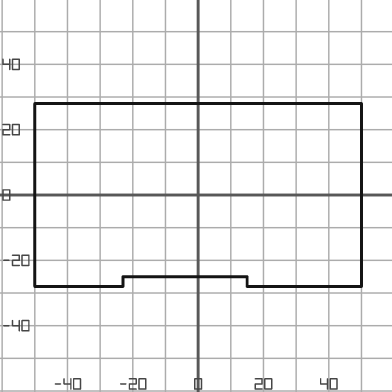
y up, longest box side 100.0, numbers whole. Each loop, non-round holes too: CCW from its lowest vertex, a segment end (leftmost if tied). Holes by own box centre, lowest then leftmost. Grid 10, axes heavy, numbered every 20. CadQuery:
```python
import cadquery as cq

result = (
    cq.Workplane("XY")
    .moveTo(-50.0, -28.0)
    .lineTo(-23.0, -28.0)
    .lineTo(-23.0, -25.0)
    .lineTo(15.0, -25.0)
    .lineTo(15.0, -28.0)
    .lineTo(50.0, -28.0)
    .lineTo(50.0, 28.0)
    .lineTo(-50.0, 28.0)
    .close()
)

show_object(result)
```